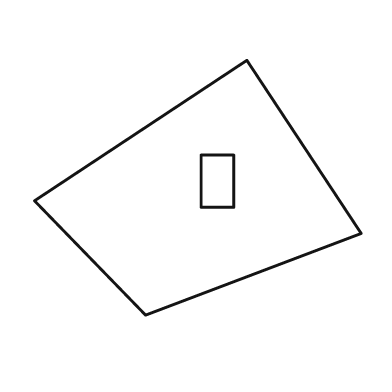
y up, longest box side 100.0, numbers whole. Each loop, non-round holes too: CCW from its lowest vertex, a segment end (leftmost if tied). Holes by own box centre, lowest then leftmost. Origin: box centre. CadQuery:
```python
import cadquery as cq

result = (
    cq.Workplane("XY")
    .moveTo(-16.0, -39.0)
    .lineTo(50.0, -14.0)
    .lineTo(15.0, 39.0)
    .lineTo(-50.0, -4.0)
    .close()
    .moveTo(1.0, -6.0)
    .lineTo(11.0, -6.0)
    .lineTo(11.0, 10.0)
    .lineTo(1.0, 10.0)
    .close()
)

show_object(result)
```